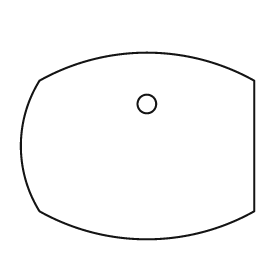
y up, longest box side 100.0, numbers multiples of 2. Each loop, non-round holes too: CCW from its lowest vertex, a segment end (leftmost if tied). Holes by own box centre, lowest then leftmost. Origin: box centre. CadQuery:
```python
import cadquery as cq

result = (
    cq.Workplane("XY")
    .moveTo(-42.0, -28.0)
    .threePointArc((4.0, -40.0), (50.0, -28.0))
    .lineTo(50.0, 28.0)
    .threePointArc((4.0, 40.0), (-42.0, 28.0))
    .threePointArc((-50.0, 0.0), (-42.0, -28.0))
    .close()
    .moveTo(4.0, 18.0)
    .circle(4.0)
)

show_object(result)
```